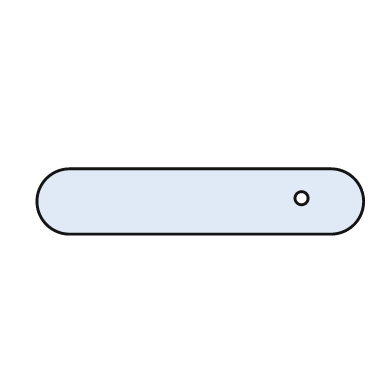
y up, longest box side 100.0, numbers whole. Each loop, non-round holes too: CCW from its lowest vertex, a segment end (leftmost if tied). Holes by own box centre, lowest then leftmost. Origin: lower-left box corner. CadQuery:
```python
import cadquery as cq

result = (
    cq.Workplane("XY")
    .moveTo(10.0, 0.0)
    .lineTo(90.0, 0.0)
    .threePointArc((100.0, 10.0), (90.0, 20.0))
    .lineTo(10.0, 20.0)
    .threePointArc((0.0, 10.0), (10.0, 0.0))
    .close()
    .moveTo(81.0, 11.0)
    .circle(2.0)
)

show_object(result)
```